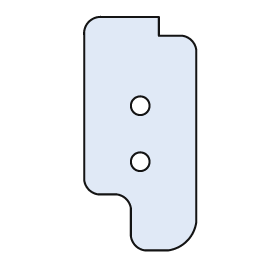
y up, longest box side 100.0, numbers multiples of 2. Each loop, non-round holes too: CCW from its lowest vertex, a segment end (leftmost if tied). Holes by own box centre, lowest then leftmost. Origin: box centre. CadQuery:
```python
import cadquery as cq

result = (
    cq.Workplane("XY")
    .moveTo(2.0, -50.0)
    .lineTo(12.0, -50.0)
    .threePointArc((20.0, -46.0), (24.0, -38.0))
    .lineTo(24.0, 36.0)
    .threePointArc((22.0, 40.0), (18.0, 42.0))
    .lineTo(8.0, 42.0)
    .lineTo(8.0, 50.0)
    .lineTo(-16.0, 50.0)
    .threePointArc((-22.0, 48.0), (-24.0, 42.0))
    .lineTo(-24.0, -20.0)
    .threePointArc((-22.0, -24.0), (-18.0, -26.0))
    .lineTo(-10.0, -26.0)
    .threePointArc((-6.0, -28.0), (-4.0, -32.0))
    .lineTo(-4.0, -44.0)
    .threePointArc((-2.0, -48.0), (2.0, -50.0))
    .close()
    .moveTo(0.0, -12.0)
    .circle(4.0)
    .moveTo(0.0, 12.0)
    .circle(4.0)
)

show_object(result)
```